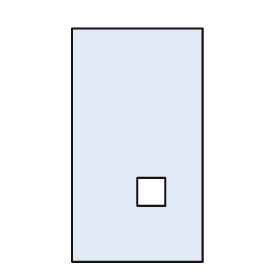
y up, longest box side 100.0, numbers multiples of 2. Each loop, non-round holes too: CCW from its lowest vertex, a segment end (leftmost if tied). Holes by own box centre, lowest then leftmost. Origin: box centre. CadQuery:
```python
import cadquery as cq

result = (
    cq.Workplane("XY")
    .moveTo(-28.0, -50.0)
    .lineTo(28.0, -50.0)
    .lineTo(28.0, 50.0)
    .lineTo(-28.0, 50.0)
    .close()
    .moveTo(0.0, -26.0)
    .lineTo(12.0, -26.0)
    .lineTo(12.0, -14.0)
    .lineTo(0.0, -14.0)
    .close()
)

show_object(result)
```